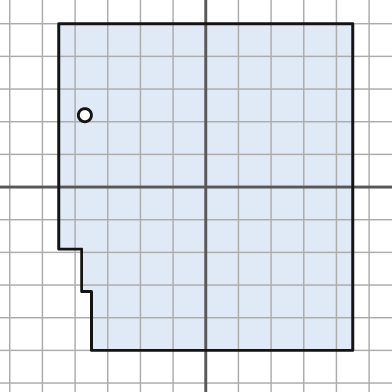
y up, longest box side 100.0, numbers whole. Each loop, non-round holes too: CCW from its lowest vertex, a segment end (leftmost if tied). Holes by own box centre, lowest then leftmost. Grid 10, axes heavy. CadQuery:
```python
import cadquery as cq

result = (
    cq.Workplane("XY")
    .moveTo(-35.0, -50.0)
    .lineTo(45.0, -50.0)
    .lineTo(45.0, 50.0)
    .lineTo(-45.0, 50.0)
    .lineTo(-45.0, -19.0)
    .lineTo(-38.0, -19.0)
    .lineTo(-38.0, -32.0)
    .lineTo(-35.0, -32.0)
    .close()
    .moveTo(-37.0, 22.0)
    .circle(2.0)
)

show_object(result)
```